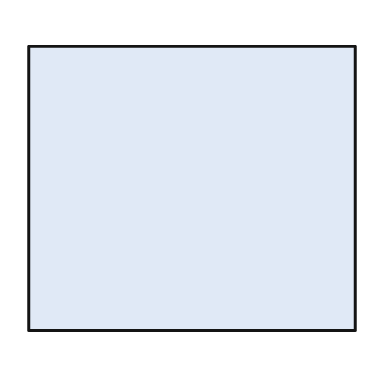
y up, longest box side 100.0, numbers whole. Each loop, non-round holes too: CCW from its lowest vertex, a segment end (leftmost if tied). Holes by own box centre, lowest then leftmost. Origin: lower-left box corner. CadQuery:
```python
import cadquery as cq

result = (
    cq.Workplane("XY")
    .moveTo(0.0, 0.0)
    .lineTo(100.0, 0.0)
    .lineTo(100.0, 87.0)
    .lineTo(0.0, 87.0)
    .close()
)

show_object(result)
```